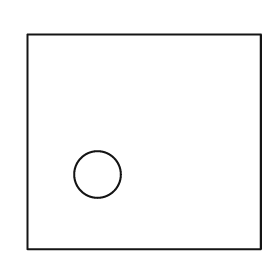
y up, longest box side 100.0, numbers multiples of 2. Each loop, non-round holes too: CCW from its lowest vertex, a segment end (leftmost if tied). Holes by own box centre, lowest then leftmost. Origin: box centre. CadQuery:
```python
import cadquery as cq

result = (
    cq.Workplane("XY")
    .moveTo(-50.0, -46.0)
    .lineTo(50.0, -46.0)
    .lineTo(50.0, 46.0)
    .lineTo(-50.0, 46.0)
    .close()
    .moveTo(-20.0, -14.0)
    .circle(10.0)
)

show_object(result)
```